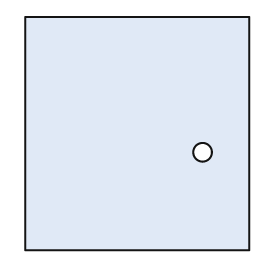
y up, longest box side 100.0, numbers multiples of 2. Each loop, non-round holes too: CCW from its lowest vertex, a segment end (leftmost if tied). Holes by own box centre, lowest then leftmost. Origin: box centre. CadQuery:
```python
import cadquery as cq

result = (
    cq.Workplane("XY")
    .moveTo(-48.0, -50.0)
    .lineTo(48.0, -50.0)
    .lineTo(48.0, 50.0)
    .lineTo(-48.0, 50.0)
    .close()
    .moveTo(28.0, -8.0)
    .circle(4.0)
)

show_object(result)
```